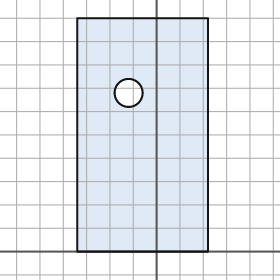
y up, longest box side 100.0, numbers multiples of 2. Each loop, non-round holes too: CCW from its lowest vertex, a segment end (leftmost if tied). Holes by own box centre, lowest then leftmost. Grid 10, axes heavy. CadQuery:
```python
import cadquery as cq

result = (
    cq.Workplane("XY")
    .moveTo(-34.0, 0.0)
    .lineTo(22.0, 0.0)
    .lineTo(22.0, 100.0)
    .lineTo(-34.0, 100.0)
    .close()
    .moveTo(-12.0, 68.0)
    .circle(6.0)
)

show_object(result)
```